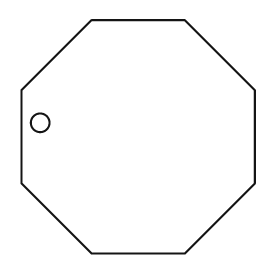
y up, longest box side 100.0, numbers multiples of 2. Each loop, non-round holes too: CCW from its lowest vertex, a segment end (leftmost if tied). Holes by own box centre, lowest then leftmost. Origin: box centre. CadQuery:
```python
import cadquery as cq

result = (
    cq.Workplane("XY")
    .moveTo(-20.0, -50.0)
    .lineTo(20.0, -50.0)
    .lineTo(50.0, -20.0)
    .lineTo(50.0, 20.0)
    .lineTo(20.0, 50.0)
    .lineTo(-20.0, 50.0)
    .lineTo(-50.0, 20.0)
    .lineTo(-50.0, -20.0)
    .close()
    .moveTo(-42.0, 6.0)
    .circle(4.0)
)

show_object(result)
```